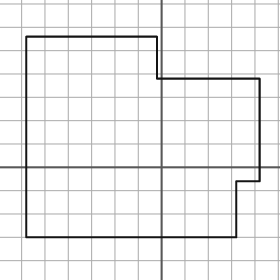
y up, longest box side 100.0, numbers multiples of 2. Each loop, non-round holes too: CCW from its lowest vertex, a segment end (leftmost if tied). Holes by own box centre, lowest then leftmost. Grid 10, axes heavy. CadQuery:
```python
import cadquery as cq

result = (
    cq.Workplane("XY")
    .moveTo(-58.0, -30.0)
    .lineTo(32.0, -30.0)
    .lineTo(32.0, -6.0)
    .lineTo(42.0, -6.0)
    .lineTo(42.0, 38.0)
    .lineTo(-2.0, 38.0)
    .lineTo(-2.0, 56.0)
    .lineTo(-58.0, 56.0)
    .close()
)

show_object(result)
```